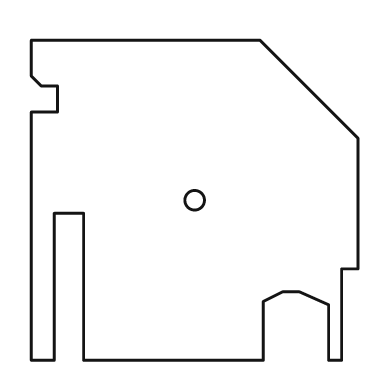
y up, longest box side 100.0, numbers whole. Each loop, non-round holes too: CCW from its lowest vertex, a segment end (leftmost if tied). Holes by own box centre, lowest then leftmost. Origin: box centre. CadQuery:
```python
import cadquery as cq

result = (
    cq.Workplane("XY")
    .moveTo(-50.0, -49.0)
    .lineTo(-43.0, -49.0)
    .lineTo(-43.0, -4.0)
    .lineTo(-34.0, -4.0)
    .lineTo(-34.0, -49.0)
    .lineTo(21.0, -49.0)
    .lineTo(21.0, -31.0)
    .lineTo(27.0, -28.0)
    .lineTo(32.0, -28.0)
    .lineTo(41.0, -32.0)
    .lineTo(41.0, -49.0)
    .lineTo(45.0, -49.0)
    .lineTo(45.0, -21.0)
    .lineTo(50.0, -21.0)
    .lineTo(50.0, 19.0)
    .lineTo(20.0, 49.0)
    .lineTo(-50.0, 49.0)
    .lineTo(-50.0, 38.0)
    .lineTo(-47.0, 35.0)
    .lineTo(-42.0, 35.0)
    .lineTo(-42.0, 27.0)
    .lineTo(-50.0, 27.0)
    .close()
    .moveTo(0.0, 0.0)
    .circle(3.0)
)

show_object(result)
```